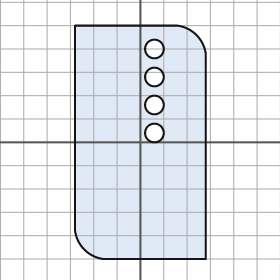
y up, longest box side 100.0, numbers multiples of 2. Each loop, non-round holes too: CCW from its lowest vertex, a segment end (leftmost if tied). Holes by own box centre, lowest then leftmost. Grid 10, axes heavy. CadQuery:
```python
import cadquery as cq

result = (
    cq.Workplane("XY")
    .moveTo(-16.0, -50.0)
    .lineTo(28.0, -50.0)
    .lineTo(28.0, 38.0)
    .threePointArc((24.0, 46.0), (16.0, 50.0))
    .lineTo(-28.0, 50.0)
    .lineTo(-28.0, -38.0)
    .threePointArc((-24.0, -46.0), (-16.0, -50.0))
    .close()
    .moveTo(6.0, 4.0)
    .circle(4.0)
    .moveTo(6.0, 16.0)
    .circle(4.0)
    .moveTo(6.0, 28.0)
    .circle(4.0)
    .moveTo(6.0, 40.0)
    .circle(4.0)
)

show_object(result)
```